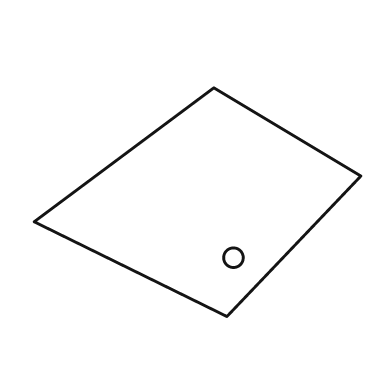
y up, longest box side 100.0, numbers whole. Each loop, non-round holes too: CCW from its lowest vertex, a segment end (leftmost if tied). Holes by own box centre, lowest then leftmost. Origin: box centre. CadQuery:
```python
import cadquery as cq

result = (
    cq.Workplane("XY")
    .moveTo(9.0, -35.0)
    .lineTo(50.0, 8.0)
    .lineTo(5.0, 35.0)
    .lineTo(-50.0, -6.0)
    .close()
    .moveTo(11.0, -17.0)
    .circle(3.0)
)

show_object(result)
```